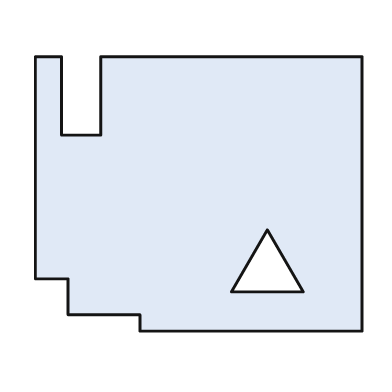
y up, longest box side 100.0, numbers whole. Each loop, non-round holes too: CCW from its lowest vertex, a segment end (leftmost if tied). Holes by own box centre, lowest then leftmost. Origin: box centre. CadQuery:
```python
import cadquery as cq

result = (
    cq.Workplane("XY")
    .moveTo(-18.0, -42.0)
    .lineTo(50.0, -42.0)
    .lineTo(50.0, 42.0)
    .lineTo(-30.0, 42.0)
    .lineTo(-30.0, 18.0)
    .lineTo(-42.0, 18.0)
    .lineTo(-42.0, 42.0)
    .lineTo(-50.0, 42.0)
    .lineTo(-50.0, -26.0)
    .lineTo(-40.0, -26.0)
    .lineTo(-40.0, -37.0)
    .lineTo(-18.0, -37.0)
    .close()
    .moveTo(10.0, -30.0)
    .lineTo(32.0, -30.0)
    .lineTo(21.0, -11.0)
    .close()
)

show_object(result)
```